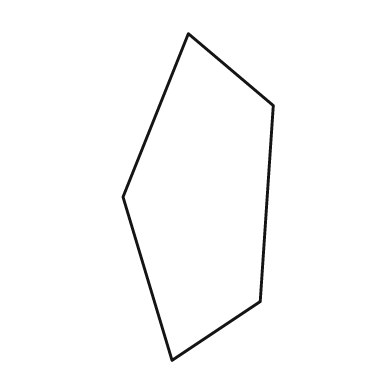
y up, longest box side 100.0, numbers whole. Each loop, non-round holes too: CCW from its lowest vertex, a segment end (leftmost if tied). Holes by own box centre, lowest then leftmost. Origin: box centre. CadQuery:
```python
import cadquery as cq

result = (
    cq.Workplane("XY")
    .moveTo(-8.0, -50.0)
    .lineTo(19.0, -32.0)
    .lineTo(23.0, 28.0)
    .lineTo(-3.0, 50.0)
    .lineTo(-23.0, 0.0)
    .close()
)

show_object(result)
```